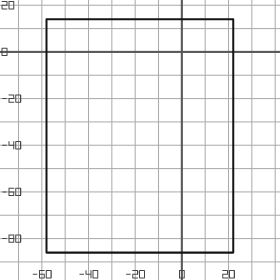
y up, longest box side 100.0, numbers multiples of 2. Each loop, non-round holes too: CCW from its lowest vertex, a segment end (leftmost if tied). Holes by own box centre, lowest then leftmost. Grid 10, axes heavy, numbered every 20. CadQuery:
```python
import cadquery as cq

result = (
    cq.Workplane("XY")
    .moveTo(-58.0, -86.0)
    .lineTo(22.0, -86.0)
    .lineTo(22.0, 14.0)
    .lineTo(-58.0, 14.0)
    .close()
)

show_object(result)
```